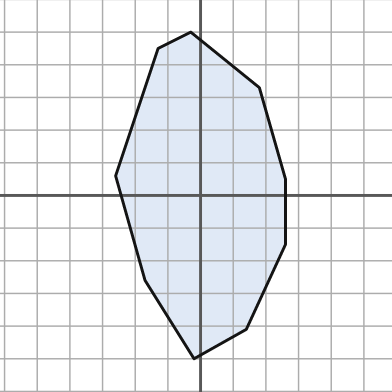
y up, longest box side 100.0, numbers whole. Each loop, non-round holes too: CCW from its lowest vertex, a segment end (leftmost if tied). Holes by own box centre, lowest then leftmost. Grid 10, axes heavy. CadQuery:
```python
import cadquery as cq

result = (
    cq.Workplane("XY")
    .moveTo(-2.0, -50.0)
    .lineTo(14.0, -41.0)
    .lineTo(26.0, -15.0)
    .lineTo(26.0, 5.0)
    .lineTo(18.0, 33.0)
    .lineTo(-3.0, 50.0)
    .lineTo(-13.0, 45.0)
    .lineTo(-26.0, 6.0)
    .lineTo(-17.0, -26.0)
    .close()
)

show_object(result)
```